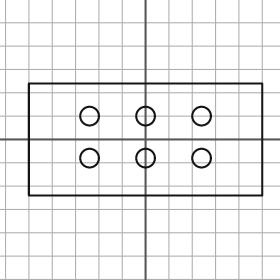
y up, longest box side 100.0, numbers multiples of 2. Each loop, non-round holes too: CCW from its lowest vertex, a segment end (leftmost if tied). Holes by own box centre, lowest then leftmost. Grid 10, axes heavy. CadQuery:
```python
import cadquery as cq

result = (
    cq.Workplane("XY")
    .moveTo(-50.0, -24.0)
    .lineTo(50.0, -24.0)
    .lineTo(50.0, 24.0)
    .lineTo(-50.0, 24.0)
    .close()
    .moveTo(-24.0, -8.0)
    .circle(4.0)
    .moveTo(0.0, -8.0)
    .circle(4.0)
    .moveTo(24.0, -8.0)
    .circle(4.0)
    .moveTo(-24.0, 10.0)
    .circle(4.0)
    .moveTo(0.0, 10.0)
    .circle(4.0)
    .moveTo(24.0, 10.0)
    .circle(4.0)
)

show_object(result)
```